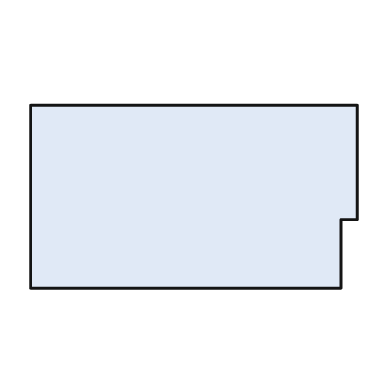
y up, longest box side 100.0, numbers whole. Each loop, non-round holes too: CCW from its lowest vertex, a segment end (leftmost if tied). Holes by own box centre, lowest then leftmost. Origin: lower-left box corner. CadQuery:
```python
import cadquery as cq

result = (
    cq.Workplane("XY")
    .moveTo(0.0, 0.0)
    .lineTo(95.0, 0.0)
    .lineTo(95.0, 21.0)
    .lineTo(100.0, 21.0)
    .lineTo(100.0, 56.0)
    .lineTo(0.0, 56.0)
    .close()
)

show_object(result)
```